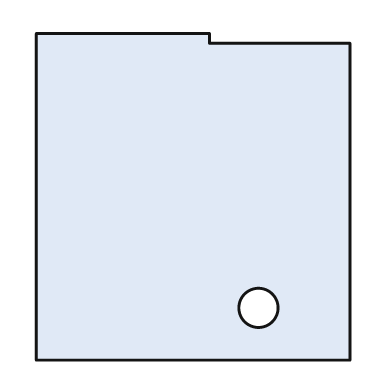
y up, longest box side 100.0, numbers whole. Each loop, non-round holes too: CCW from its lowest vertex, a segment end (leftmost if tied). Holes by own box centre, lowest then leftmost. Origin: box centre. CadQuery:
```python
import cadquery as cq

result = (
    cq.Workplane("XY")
    .moveTo(-48.0, -50.0)
    .lineTo(48.0, -50.0)
    .lineTo(48.0, 47.0)
    .lineTo(5.0, 47.0)
    .lineTo(5.0, 50.0)
    .lineTo(-48.0, 50.0)
    .close()
    .moveTo(20.0, -34.0)
    .circle(6.0)
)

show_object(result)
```